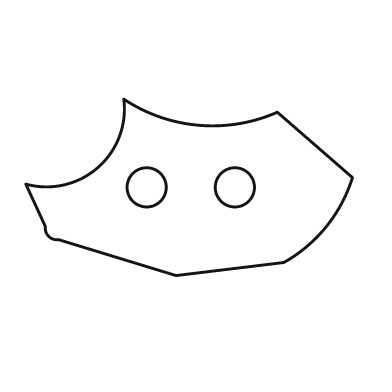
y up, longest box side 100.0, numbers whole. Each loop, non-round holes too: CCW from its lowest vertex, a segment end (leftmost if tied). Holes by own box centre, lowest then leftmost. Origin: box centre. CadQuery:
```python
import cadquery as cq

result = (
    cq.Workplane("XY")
    .moveTo(-4.0, -27.0)
    .lineTo(29.0, -23.0)
    .threePointArc((42.0, -12.0), (50.0, 3.0))
    .lineTo(27.0, 23.0)
    .threePointArc((3.0, 19.0), (-20.0, 27.0))
    .threePointArc((-28.0, 6.0), (-50.0, 1.0))
    .lineTo(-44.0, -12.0)
    .threePointArc((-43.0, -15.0), (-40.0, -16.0))
    .close()
    .moveTo(-13.0, 0.0)
    .circle(6.0)
    .moveTo(14.0, 0.0)
    .circle(6.0)
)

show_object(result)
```